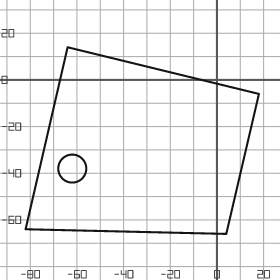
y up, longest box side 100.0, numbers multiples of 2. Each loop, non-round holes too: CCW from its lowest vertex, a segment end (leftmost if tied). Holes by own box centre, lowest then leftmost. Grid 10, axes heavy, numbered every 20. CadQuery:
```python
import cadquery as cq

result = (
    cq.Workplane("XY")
    .moveTo(4.0, -66.0)
    .lineTo(18.0, -6.0)
    .lineTo(-64.0, 14.0)
    .lineTo(-82.0, -64.0)
    .close()
    .moveTo(-62.0, -38.0)
    .circle(6.0)
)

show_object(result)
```